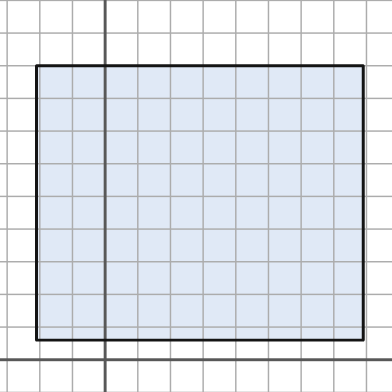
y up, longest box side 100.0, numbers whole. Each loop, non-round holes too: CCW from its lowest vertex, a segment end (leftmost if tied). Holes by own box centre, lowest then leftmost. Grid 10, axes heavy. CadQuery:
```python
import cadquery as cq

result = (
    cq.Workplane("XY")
    .moveTo(-21.0, 6.0)
    .lineTo(79.0, 6.0)
    .lineTo(79.0, 90.0)
    .lineTo(-21.0, 90.0)
    .close()
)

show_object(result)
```